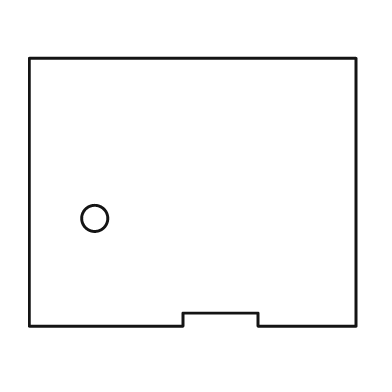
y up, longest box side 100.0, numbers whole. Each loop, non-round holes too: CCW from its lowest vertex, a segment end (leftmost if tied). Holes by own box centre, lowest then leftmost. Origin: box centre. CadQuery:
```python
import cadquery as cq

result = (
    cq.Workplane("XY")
    .moveTo(-50.0, -41.0)
    .lineTo(-3.0, -41.0)
    .lineTo(-3.0, -37.0)
    .lineTo(20.0, -37.0)
    .lineTo(20.0, -41.0)
    .lineTo(50.0, -41.0)
    .lineTo(50.0, 41.0)
    .lineTo(-50.0, 41.0)
    .close()
    .moveTo(-30.0, -8.0)
    .circle(4.0)
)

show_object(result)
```